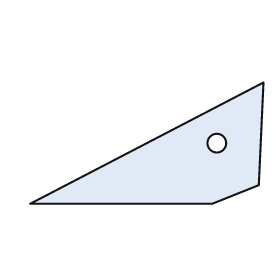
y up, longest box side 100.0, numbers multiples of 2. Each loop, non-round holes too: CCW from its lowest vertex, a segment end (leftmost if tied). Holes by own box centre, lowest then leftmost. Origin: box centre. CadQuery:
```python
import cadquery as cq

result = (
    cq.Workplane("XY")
    .moveTo(-50.0, -26.0)
    .lineTo(28.0, -26.0)
    .lineTo(48.0, -18.0)
    .lineTo(50.0, 26.0)
    .close()
    .moveTo(30.0, 0.0)
    .circle(4.0)
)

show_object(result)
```